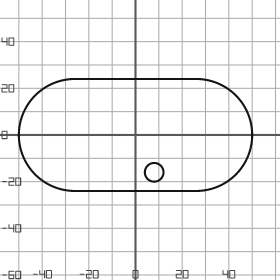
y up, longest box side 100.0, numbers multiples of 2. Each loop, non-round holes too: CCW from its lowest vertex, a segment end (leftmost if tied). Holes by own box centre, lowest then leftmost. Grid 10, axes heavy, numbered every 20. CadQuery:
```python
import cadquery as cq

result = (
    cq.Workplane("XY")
    .moveTo(-26.0, -24.0)
    .lineTo(26.0, -24.0)
    .threePointArc((50.0, 0.0), (26.0, 24.0))
    .lineTo(-26.0, 24.0)
    .threePointArc((-50.0, 0.0), (-26.0, -24.0))
    .close()
    .moveTo(8.0, -16.0)
    .circle(4.0)
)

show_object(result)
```